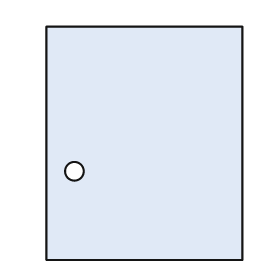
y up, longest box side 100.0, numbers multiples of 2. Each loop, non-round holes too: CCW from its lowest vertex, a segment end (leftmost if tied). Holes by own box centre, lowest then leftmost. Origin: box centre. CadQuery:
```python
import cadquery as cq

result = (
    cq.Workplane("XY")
    .moveTo(-42.0, -50.0)
    .lineTo(42.0, -50.0)
    .lineTo(42.0, 50.0)
    .lineTo(-42.0, 50.0)
    .close()
    .moveTo(-30.0, -12.0)
    .circle(4.0)
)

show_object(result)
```